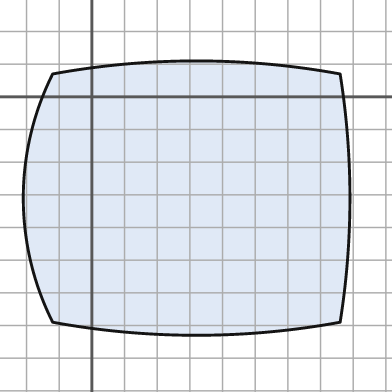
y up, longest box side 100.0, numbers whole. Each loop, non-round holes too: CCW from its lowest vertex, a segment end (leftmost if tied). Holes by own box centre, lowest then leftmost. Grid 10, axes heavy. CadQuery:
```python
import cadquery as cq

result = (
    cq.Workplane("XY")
    .moveTo(-12.0, -69.0)
    .threePointArc((32.0, -73.0), (76.0, -69.0))
    .threePointArc((79.0, -31.0), (76.0, 7.0))
    .threePointArc((32.0, 11.0), (-12.0, 7.0))
    .threePointArc((-21.0, -31.0), (-12.0, -69.0))
    .close()
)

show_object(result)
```